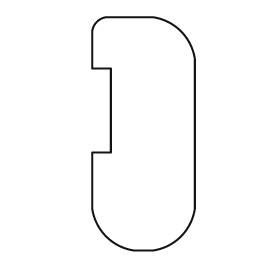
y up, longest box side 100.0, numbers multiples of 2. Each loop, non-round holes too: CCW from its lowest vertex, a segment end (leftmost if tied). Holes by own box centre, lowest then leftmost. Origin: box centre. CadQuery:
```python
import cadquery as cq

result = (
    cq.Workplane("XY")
    .moveTo(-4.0, -50.0)
    .lineTo(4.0, -50.0)
    .threePointArc((16.0, -44.0), (22.0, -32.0))
    .lineTo(22.0, 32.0)
    .threePointArc((16.0, 44.0), (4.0, 50.0))
    .lineTo(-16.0, 50.0)
    .threePointArc((-20.0, 48.0), (-22.0, 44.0))
    .lineTo(-22.0, 28.0)
    .lineTo(-14.0, 28.0)
    .lineTo(-14.0, -8.0)
    .lineTo(-22.0, -8.0)
    .lineTo(-22.0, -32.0)
    .threePointArc((-16.0, -44.0), (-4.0, -50.0))
    .close()
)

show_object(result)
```